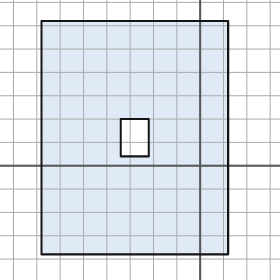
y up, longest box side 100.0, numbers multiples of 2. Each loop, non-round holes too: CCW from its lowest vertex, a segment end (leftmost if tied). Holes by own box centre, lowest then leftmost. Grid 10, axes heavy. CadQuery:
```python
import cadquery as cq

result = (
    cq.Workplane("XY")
    .moveTo(-68.0, -38.0)
    .lineTo(12.0, -38.0)
    .lineTo(12.0, 62.0)
    .lineTo(-68.0, 62.0)
    .close()
    .moveTo(-34.0, 4.0)
    .lineTo(-22.0, 4.0)
    .lineTo(-22.0, 20.0)
    .lineTo(-34.0, 20.0)
    .close()
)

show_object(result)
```